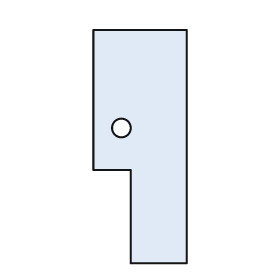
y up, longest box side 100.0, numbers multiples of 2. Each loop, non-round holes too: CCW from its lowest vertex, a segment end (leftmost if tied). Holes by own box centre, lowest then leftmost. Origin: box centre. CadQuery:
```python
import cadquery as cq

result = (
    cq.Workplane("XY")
    .moveTo(-4.0, -50.0)
    .lineTo(20.0, -50.0)
    .lineTo(20.0, 50.0)
    .lineTo(-20.0, 50.0)
    .lineTo(-20.0, -10.0)
    .lineTo(-4.0, -10.0)
    .close()
    .moveTo(-8.0, 8.0)
    .circle(4.0)
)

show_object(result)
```